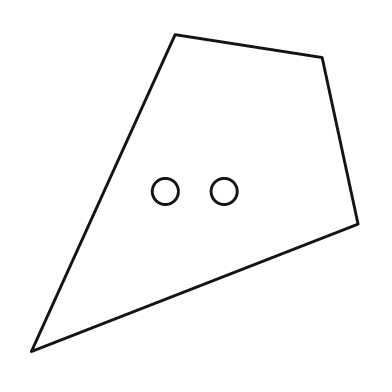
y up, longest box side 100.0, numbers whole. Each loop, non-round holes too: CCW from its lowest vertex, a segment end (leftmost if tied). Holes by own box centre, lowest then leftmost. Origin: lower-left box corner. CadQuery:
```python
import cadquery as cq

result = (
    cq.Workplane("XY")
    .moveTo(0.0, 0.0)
    .lineTo(100.0, 39.0)
    .lineTo(89.0, 90.0)
    .lineTo(44.0, 97.0)
    .close()
    .moveTo(41.0, 49.0)
    .circle(4.0)
    .moveTo(59.0, 49.0)
    .circle(4.0)
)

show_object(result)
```